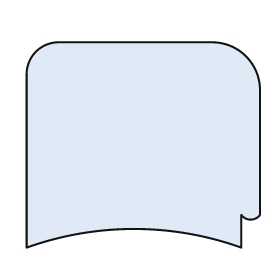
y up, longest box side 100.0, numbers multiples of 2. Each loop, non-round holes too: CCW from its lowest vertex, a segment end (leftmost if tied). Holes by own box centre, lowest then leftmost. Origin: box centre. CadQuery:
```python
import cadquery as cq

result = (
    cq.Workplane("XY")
    .moveTo(-50.0, -44.0)
    .threePointArc((-4.0, -36.0), (42.0, -44.0))
    .lineTo(42.0, -30.0)
    .threePointArc((46.0, -32.0), (50.0, -30.0))
    .lineTo(50.0, 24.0)
    .threePointArc((44.0, 38.0), (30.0, 44.0))
    .lineTo(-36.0, 44.0)
    .threePointArc((-46.0, 40.0), (-50.0, 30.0))
    .close()
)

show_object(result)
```